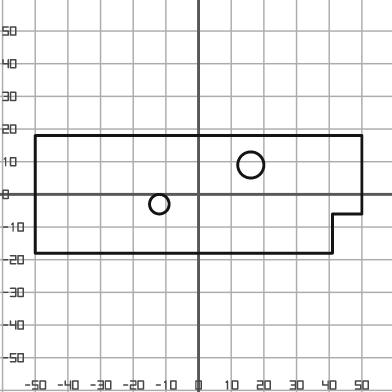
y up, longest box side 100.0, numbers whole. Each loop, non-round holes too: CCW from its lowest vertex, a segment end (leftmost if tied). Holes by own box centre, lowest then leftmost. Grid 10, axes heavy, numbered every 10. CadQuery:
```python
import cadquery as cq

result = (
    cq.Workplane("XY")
    .moveTo(-50.0, -18.0)
    .lineTo(41.0, -18.0)
    .lineTo(41.0, -6.0)
    .lineTo(50.0, -6.0)
    .lineTo(50.0, 18.0)
    .lineTo(-50.0, 18.0)
    .close()
    .moveTo(-12.0, -3.0)
    .circle(3.0)
    .moveTo(16.0, 9.0)
    .circle(4.0)
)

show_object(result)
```